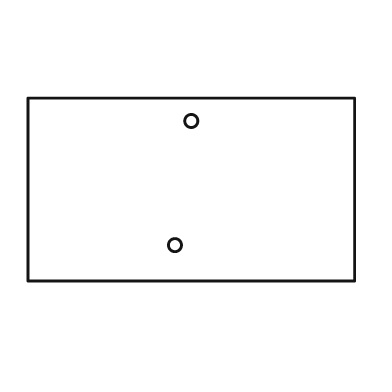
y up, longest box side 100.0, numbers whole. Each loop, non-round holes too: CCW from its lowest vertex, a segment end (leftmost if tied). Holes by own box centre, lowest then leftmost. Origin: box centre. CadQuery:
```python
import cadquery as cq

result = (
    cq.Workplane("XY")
    .moveTo(-50.0, -28.0)
    .lineTo(50.0, -28.0)
    .lineTo(50.0, 28.0)
    .lineTo(-50.0, 28.0)
    .close()
    .moveTo(-5.0, -17.0)
    .circle(2.0)
    .moveTo(0.0, 21.0)
    .circle(2.0)
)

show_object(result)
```